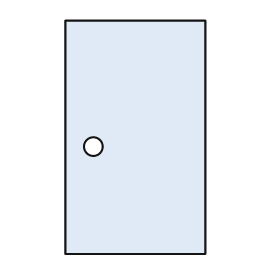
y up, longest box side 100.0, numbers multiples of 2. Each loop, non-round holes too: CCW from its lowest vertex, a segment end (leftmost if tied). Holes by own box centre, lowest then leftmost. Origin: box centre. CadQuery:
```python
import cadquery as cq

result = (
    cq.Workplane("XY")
    .moveTo(-30.0, -50.0)
    .lineTo(30.0, -50.0)
    .lineTo(30.0, 50.0)
    .lineTo(-30.0, 50.0)
    .close()
    .moveTo(-18.0, -4.0)
    .circle(4.0)
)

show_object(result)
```